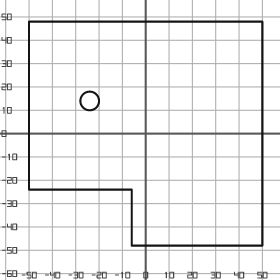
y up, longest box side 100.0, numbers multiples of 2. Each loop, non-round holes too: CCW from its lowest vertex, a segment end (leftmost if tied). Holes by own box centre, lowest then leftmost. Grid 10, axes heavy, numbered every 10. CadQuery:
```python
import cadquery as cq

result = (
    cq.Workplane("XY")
    .moveTo(-6.0, -48.0)
    .lineTo(50.0, -48.0)
    .lineTo(50.0, 48.0)
    .lineTo(-50.0, 48.0)
    .lineTo(-50.0, -24.0)
    .lineTo(-6.0, -24.0)
    .close()
    .moveTo(-24.0, 14.0)
    .circle(4.0)
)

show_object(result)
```